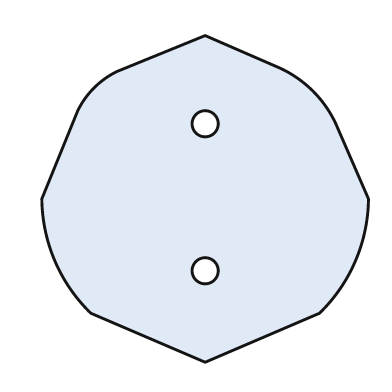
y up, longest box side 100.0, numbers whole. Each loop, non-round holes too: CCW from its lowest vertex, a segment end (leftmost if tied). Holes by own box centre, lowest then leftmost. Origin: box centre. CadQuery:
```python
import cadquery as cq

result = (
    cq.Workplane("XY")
    .moveTo(0.0, -50.0)
    .lineTo(35.0, -35.0)
    .threePointArc((46.0, -19.0), (50.0, 0.0))
    .lineTo(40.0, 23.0)
    .threePointArc((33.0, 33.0), (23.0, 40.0))
    .lineTo(0.0, 50.0)
    .lineTo(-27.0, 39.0)
    .threePointArc((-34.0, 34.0), (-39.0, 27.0))
    .lineTo(-50.0, 0.0)
    .threePointArc((-46.0, -19.0), (-35.0, -35.0))
    .close()
    .moveTo(0.0, -22.0)
    .circle(4.0)
    .moveTo(0.0, 23.0)
    .circle(4.0)
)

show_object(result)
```